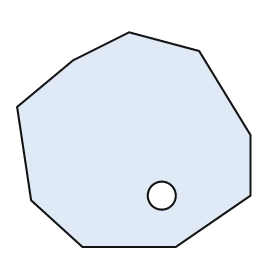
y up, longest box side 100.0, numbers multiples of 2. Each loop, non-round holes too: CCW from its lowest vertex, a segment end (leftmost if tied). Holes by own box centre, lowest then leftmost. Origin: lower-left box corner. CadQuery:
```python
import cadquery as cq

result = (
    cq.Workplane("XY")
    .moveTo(28.0, 0.0)
    .lineTo(68.0, 0.0)
    .lineTo(100.0, 22.0)
    .lineTo(100.0, 48.0)
    .lineTo(78.0, 84.0)
    .lineTo(48.0, 92.0)
    .lineTo(24.0, 80.0)
    .lineTo(0.0, 60.0)
    .lineTo(6.0, 20.0)
    .close()
    .moveTo(62.0, 22.0)
    .circle(6.0)
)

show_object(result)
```